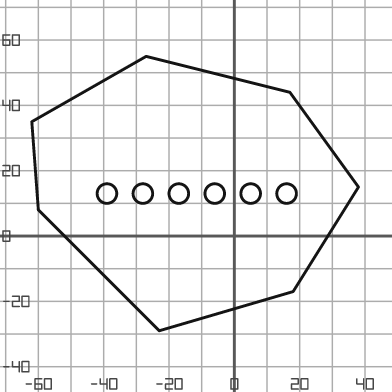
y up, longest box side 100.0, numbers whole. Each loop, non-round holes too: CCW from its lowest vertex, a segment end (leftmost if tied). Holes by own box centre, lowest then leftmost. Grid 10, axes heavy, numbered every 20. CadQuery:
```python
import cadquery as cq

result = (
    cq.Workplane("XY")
    .moveTo(-23.0, -29.0)
    .lineTo(18.0, -17.0)
    .lineTo(38.0, 15.0)
    .lineTo(17.0, 44.0)
    .lineTo(-27.0, 55.0)
    .lineTo(-62.0, 35.0)
    .lineTo(-60.0, 8.0)
    .close()
    .moveTo(-39.0, 13.0)
    .circle(3.0)
    .moveTo(-28.0, 13.0)
    .circle(3.0)
    .moveTo(-17.0, 13.0)
    .circle(3.0)
    .moveTo(-6.0, 13.0)
    .circle(3.0)
    .moveTo(5.0, 13.0)
    .circle(3.0)
    .moveTo(16.0, 13.0)
    .circle(3.0)
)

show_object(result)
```